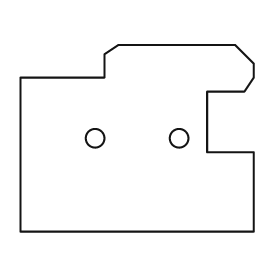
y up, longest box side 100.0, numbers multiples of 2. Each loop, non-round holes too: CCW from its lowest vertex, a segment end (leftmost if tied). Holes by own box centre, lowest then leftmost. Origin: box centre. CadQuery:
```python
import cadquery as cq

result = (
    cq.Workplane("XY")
    .moveTo(-50.0, -40.0)
    .lineTo(50.0, -40.0)
    .lineTo(50.0, -6.0)
    .lineTo(30.0, -6.0)
    .lineTo(30.0, 20.0)
    .lineTo(46.0, 20.0)
    .lineTo(50.0, 26.0)
    .lineTo(50.0, 32.0)
    .lineTo(42.0, 40.0)
    .lineTo(-8.0, 40.0)
    .lineTo(-14.0, 36.0)
    .lineTo(-14.0, 26.0)
    .lineTo(-50.0, 26.0)
    .close()
    .moveTo(-18.0, 0.0)
    .circle(4.0)
    .moveTo(18.0, 0.0)
    .circle(4.0)
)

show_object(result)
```